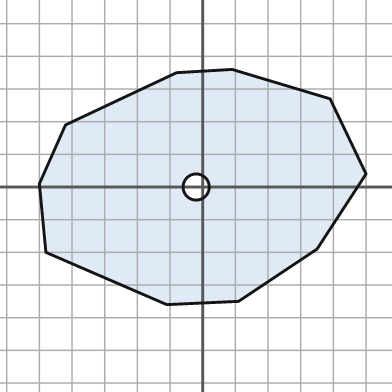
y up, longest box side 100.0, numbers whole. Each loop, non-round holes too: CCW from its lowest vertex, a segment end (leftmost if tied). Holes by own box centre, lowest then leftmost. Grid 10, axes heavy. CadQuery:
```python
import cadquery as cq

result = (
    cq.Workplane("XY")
    .moveTo(-11.0, -36.0)
    .lineTo(11.0, -35.0)
    .lineTo(35.0, -19.0)
    .lineTo(50.0, 4.0)
    .lineTo(39.0, 27.0)
    .lineTo(9.0, 36.0)
    .lineTo(-8.0, 35.0)
    .lineTo(-42.0, 19.0)
    .lineTo(-50.0, 1.0)
    .lineTo(-48.0, -20.0)
    .close()
    .moveTo(-2.0, 0.0)
    .circle(4.0)
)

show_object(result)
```